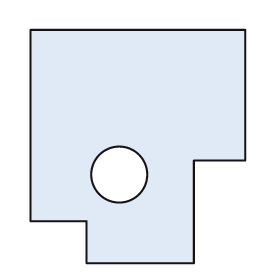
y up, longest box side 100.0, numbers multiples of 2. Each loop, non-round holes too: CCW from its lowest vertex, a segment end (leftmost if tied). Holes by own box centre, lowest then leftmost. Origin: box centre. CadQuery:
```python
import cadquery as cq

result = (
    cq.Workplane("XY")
    .moveTo(-22.0, -50.0)
    .lineTo(24.0, -50.0)
    .lineTo(24.0, -6.0)
    .lineTo(46.0, -6.0)
    .lineTo(46.0, 50.0)
    .lineTo(-46.0, 50.0)
    .lineTo(-46.0, -32.0)
    .lineTo(-22.0, -32.0)
    .close()
    .moveTo(-8.0, -12.0)
    .circle(12.0)
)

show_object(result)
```